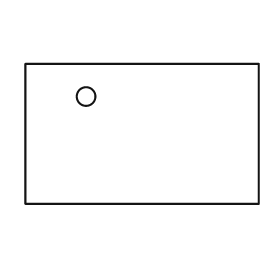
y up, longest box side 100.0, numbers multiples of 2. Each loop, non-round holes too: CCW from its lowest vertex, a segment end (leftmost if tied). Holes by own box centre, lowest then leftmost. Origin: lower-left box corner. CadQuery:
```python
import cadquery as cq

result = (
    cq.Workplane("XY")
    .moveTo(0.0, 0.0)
    .lineTo(100.0, 0.0)
    .lineTo(100.0, 60.0)
    .lineTo(0.0, 60.0)
    .close()
    .moveTo(26.0, 46.0)
    .circle(4.0)
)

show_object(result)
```